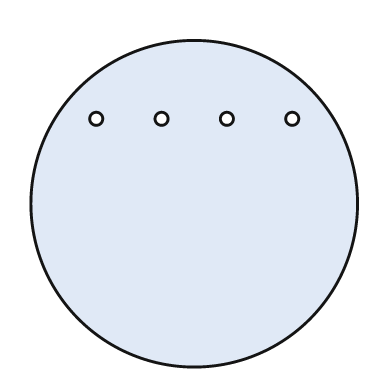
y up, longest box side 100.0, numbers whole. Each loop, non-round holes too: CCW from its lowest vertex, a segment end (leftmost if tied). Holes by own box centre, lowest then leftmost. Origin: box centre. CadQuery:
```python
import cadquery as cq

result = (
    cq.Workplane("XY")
    .moveTo(0.0, 0.0)
    .circle(50.0)
    .moveTo(-30.0, 26.0)
    .circle(2.0)
    .moveTo(-10.0, 26.0)
    .circle(2.0)
    .moveTo(10.0, 26.0)
    .circle(2.0)
    .moveTo(30.0, 26.0)
    .circle(2.0)
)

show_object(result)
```